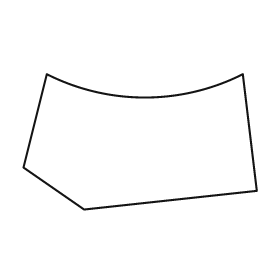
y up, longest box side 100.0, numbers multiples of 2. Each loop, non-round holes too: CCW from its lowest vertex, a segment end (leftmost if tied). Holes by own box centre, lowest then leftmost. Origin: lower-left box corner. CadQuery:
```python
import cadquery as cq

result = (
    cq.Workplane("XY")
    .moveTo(26.0, 0.0)
    .lineTo(100.0, 8.0)
    .lineTo(94.0, 58.0)
    .threePointArc((52.0, 48.0), (10.0, 58.0))
    .lineTo(0.0, 18.0)
    .close()
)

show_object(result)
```